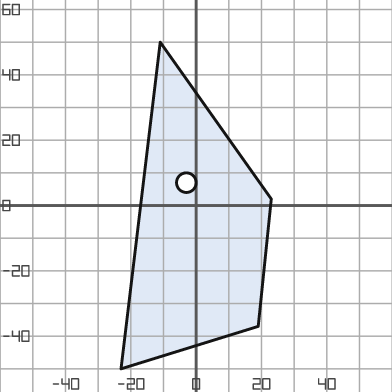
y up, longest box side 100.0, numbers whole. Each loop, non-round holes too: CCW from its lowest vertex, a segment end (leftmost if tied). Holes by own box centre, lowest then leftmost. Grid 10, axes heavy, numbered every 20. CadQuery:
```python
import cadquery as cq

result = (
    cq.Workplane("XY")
    .moveTo(-23.0, -50.0)
    .lineTo(19.0, -37.0)
    .lineTo(23.0, 2.0)
    .lineTo(-11.0, 50.0)
    .close()
    .moveTo(-3.0, 7.0)
    .circle(3.0)
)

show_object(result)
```